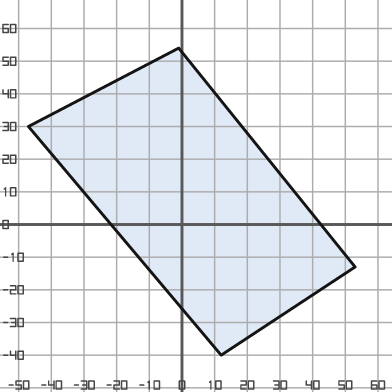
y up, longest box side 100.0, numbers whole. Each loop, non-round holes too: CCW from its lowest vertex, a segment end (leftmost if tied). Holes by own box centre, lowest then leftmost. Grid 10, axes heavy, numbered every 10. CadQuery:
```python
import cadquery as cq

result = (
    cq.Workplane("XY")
    .moveTo(12.0, -40.0)
    .lineTo(53.0, -13.0)
    .lineTo(-1.0, 54.0)
    .lineTo(-47.0, 30.0)
    .close()
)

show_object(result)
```